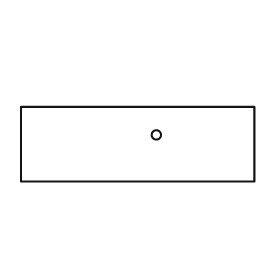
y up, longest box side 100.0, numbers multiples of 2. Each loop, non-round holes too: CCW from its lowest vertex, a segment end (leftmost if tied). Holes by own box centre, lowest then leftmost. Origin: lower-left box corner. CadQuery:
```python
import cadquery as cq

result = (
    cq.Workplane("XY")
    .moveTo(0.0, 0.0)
    .lineTo(100.0, 0.0)
    .lineTo(100.0, 32.0)
    .lineTo(0.0, 32.0)
    .close()
    .moveTo(58.0, 20.0)
    .circle(2.0)
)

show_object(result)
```